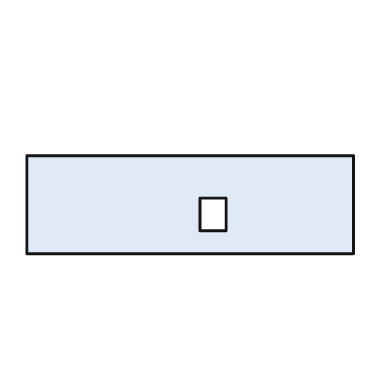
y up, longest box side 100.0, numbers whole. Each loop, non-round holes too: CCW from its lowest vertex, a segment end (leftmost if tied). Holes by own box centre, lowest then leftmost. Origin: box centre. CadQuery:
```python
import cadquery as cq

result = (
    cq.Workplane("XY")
    .moveTo(-50.0, -15.0)
    .lineTo(50.0, -15.0)
    .lineTo(50.0, 15.0)
    .lineTo(-50.0, 15.0)
    .close()
    .moveTo(3.0, -8.0)
    .lineTo(11.0, -8.0)
    .lineTo(11.0, 2.0)
    .lineTo(3.0, 2.0)
    .close()
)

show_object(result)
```